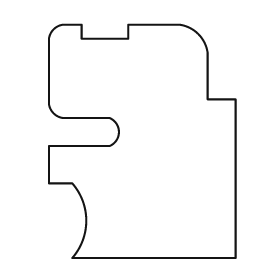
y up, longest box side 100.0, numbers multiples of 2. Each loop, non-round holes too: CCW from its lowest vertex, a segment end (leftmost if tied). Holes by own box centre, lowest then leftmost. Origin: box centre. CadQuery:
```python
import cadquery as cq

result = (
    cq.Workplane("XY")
    .moveTo(-30.0, -50.0)
    .lineTo(40.0, -50.0)
    .lineTo(40.0, 18.0)
    .lineTo(28.0, 18.0)
    .lineTo(28.0, 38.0)
    .threePointArc((24.0, 46.0), (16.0, 50.0))
    .lineTo(-6.0, 50.0)
    .lineTo(-6.0, 44.0)
    .lineTo(-26.0, 44.0)
    .lineTo(-26.0, 50.0)
    .lineTo(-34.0, 50.0)
    .threePointArc((-38.0, 48.0), (-40.0, 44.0))
    .lineTo(-40.0, 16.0)
    .threePointArc((-38.0, 12.0), (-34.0, 10.0))
    .lineTo(-14.0, 10.0)
    .threePointArc((-10.0, 4.0), (-14.0, -2.0))
    .lineTo(-40.0, -2.0)
    .lineTo(-40.0, -18.0)
    .lineTo(-30.0, -18.0)
    .threePointArc((-24.0, -34.0), (-30.0, -50.0))
    .close()
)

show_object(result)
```